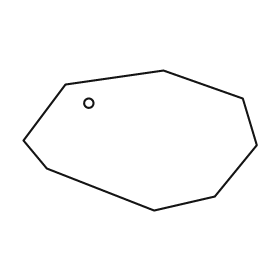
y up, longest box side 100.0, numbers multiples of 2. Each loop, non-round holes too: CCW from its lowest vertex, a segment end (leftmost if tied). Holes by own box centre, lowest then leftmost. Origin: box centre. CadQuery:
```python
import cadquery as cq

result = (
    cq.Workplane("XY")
    .moveTo(6.0, -30.0)
    .lineTo(32.0, -24.0)
    .lineTo(50.0, -2.0)
    .lineTo(44.0, 18.0)
    .lineTo(10.0, 30.0)
    .lineTo(-32.0, 24.0)
    .lineTo(-50.0, 0.0)
    .lineTo(-40.0, -12.0)
    .close()
    .moveTo(-22.0, 16.0)
    .circle(2.0)
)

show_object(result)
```